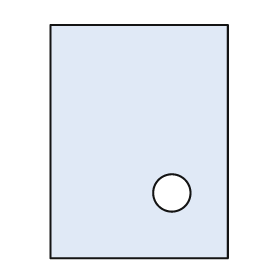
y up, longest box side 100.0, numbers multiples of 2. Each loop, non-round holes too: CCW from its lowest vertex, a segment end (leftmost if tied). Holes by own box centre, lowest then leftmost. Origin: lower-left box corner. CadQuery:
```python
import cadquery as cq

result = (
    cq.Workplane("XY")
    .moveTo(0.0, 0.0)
    .lineTo(76.0, 0.0)
    .lineTo(76.0, 100.0)
    .lineTo(0.0, 100.0)
    .close()
    .moveTo(52.0, 28.0)
    .circle(8.0)
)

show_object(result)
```